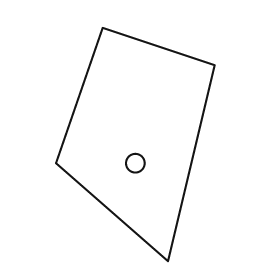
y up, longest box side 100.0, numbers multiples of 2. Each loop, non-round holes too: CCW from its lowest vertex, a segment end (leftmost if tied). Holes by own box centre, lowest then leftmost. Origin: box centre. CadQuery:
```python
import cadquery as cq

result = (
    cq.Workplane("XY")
    .moveTo(14.0, -50.0)
    .lineTo(34.0, 34.0)
    .lineTo(-14.0, 50.0)
    .lineTo(-34.0, -8.0)
    .close()
    .moveTo(0.0, -8.0)
    .circle(4.0)
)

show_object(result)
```